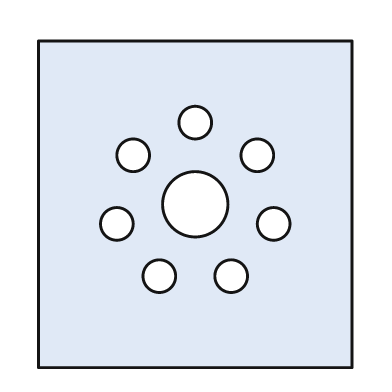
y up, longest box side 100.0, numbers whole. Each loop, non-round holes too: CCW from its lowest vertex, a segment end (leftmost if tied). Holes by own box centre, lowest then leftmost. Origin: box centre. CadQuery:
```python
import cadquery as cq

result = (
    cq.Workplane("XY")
    .moveTo(-48.0, -50.0)
    .lineTo(48.0, -50.0)
    .lineTo(48.0, 50.0)
    .lineTo(-48.0, 50.0)
    .close()
    .moveTo(-11.0, -22.0)
    .circle(5.0)
    .moveTo(11.0, -22.0)
    .circle(5.0)
    .moveTo(-24.0, -6.0)
    .circle(5.0)
    .moveTo(24.0, -6.0)
    .circle(5.0)
    .moveTo(0.0, 0.0)
    .circle(10.0)
    .moveTo(-19.0, 15.0)
    .circle(5.0)
    .moveTo(19.0, 15.0)
    .circle(5.0)
    .moveTo(0.0, 25.0)
    .circle(5.0)
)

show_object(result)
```